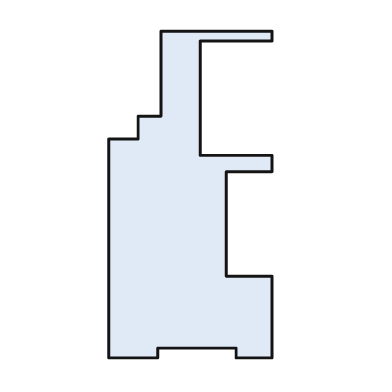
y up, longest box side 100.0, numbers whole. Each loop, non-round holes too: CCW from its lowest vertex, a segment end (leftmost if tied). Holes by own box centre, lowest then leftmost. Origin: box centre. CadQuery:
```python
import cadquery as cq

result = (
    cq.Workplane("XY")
    .moveTo(-25.0, -50.0)
    .lineTo(-10.0, -50.0)
    .lineTo(-10.0, -47.0)
    .lineTo(14.0, -47.0)
    .lineTo(14.0, -50.0)
    .lineTo(25.0, -50.0)
    .lineTo(25.0, -25.0)
    .lineTo(11.0, -25.0)
    .lineTo(11.0, 7.0)
    .lineTo(25.0, 7.0)
    .lineTo(25.0, 12.0)
    .lineTo(3.0, 12.0)
    .lineTo(3.0, 47.0)
    .lineTo(25.0, 47.0)
    .lineTo(25.0, 50.0)
    .lineTo(-9.0, 50.0)
    .lineTo(-9.0, 24.0)
    .lineTo(-16.0, 24.0)
    .lineTo(-16.0, 17.0)
    .lineTo(-25.0, 17.0)
    .close()
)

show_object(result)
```